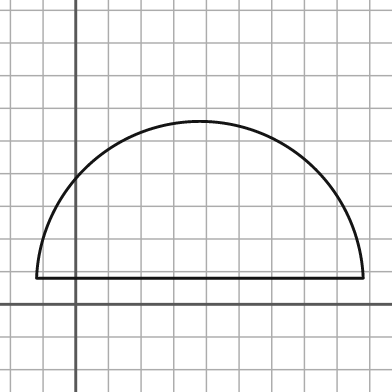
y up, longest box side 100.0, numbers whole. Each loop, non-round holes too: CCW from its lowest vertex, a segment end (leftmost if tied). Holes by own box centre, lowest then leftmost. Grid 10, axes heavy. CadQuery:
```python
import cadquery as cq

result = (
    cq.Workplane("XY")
    .moveTo(-12.0, 8.0)
    .lineTo(88.0, 8.0)
    .threePointArc((38.0, 56.0), (-12.0, 8.0))
    .close()
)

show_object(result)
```